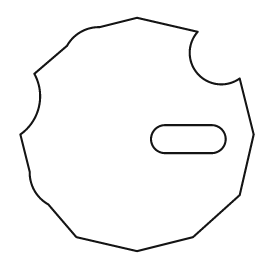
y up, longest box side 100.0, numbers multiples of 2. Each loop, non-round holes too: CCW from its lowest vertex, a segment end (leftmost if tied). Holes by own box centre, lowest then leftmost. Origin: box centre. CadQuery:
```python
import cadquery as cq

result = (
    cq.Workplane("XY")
    .moveTo(0.0, -50.0)
    .lineTo(24.0, -44.0)
    .lineTo(44.0, -26.0)
    .lineTo(50.0, 0.0)
    .lineTo(44.0, 24.0)
    .threePointArc((26.0, 26.0), (26.0, 44.0))
    .lineTo(0.0, 50.0)
    .lineTo(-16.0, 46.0)
    .threePointArc((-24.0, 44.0), (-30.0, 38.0))
    .lineTo(-44.0, 26.0)
    .threePointArc((-42.0, 12.0), (-50.0, 0.0))
    .lineTo(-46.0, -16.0)
    .threePointArc((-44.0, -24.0), (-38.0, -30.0))
    .lineTo(-26.0, -44.0)
    .close()
    .moveTo(12.0, -8.0)
    .lineTo(32.0, -8.0)
    .threePointArc((38.0, -2.0), (32.0, 4.0))
    .lineTo(12.0, 4.0)
    .threePointArc((6.0, -2.0), (12.0, -8.0))
    .close()
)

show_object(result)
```